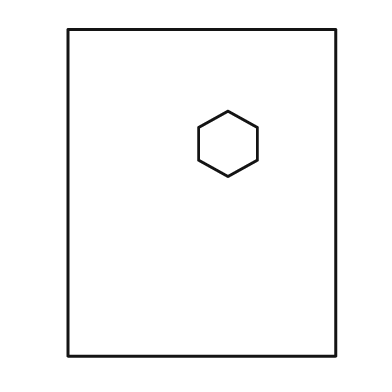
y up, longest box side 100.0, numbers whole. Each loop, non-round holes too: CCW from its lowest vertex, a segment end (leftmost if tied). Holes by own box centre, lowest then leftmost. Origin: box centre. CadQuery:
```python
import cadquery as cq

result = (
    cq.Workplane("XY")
    .moveTo(-41.0, -50.0)
    .lineTo(41.0, -50.0)
    .lineTo(41.0, 50.0)
    .lineTo(-41.0, 50.0)
    .close()
    .moveTo(8.0, 5.0)
    .lineTo(17.0, 10.0)
    .lineTo(17.0, 20.0)
    .lineTo(8.0, 25.0)
    .lineTo(-1.0, 20.0)
    .lineTo(-1.0, 10.0)
    .close()
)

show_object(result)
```